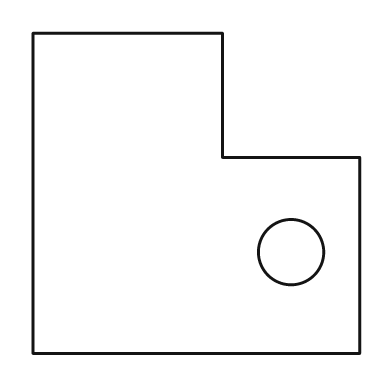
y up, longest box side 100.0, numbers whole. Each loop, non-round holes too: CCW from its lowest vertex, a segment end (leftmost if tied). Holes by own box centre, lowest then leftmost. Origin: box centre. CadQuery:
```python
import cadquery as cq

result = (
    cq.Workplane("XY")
    .moveTo(-50.0, -49.0)
    .lineTo(50.0, -49.0)
    .lineTo(50.0, 11.0)
    .lineTo(8.0, 11.0)
    .lineTo(8.0, 49.0)
    .lineTo(-50.0, 49.0)
    .close()
    .moveTo(29.0, -18.0)
    .circle(10.0)
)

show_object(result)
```